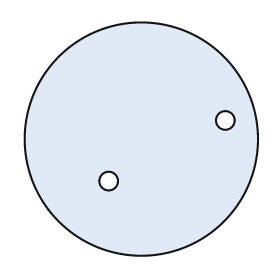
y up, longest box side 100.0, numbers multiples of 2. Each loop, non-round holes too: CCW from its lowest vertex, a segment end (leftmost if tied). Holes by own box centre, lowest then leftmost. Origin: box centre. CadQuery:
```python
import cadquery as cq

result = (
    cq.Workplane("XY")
    .moveTo(0.0, 0.0)
    .circle(50.0)
    .moveTo(-14.0, -18.0)
    .circle(4.0)
    .moveTo(36.0, 8.0)
    .circle(4.0)
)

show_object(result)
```